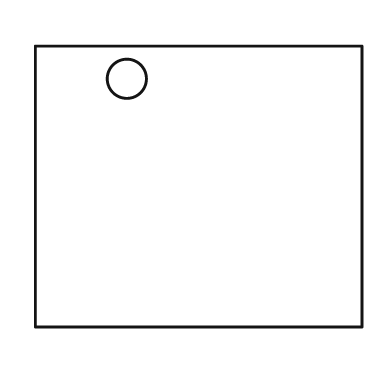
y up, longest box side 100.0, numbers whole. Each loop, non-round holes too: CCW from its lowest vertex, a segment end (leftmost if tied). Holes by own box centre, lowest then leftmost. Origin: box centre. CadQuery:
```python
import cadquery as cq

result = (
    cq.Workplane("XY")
    .moveTo(-50.0, -43.0)
    .lineTo(50.0, -43.0)
    .lineTo(50.0, 43.0)
    .lineTo(-50.0, 43.0)
    .close()
    .moveTo(-22.0, 33.0)
    .circle(6.0)
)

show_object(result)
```